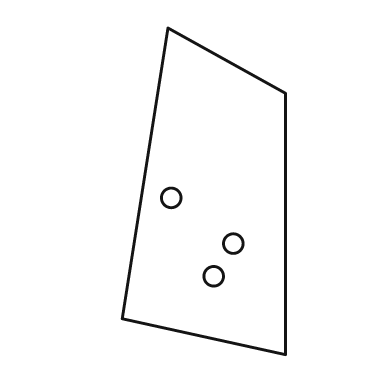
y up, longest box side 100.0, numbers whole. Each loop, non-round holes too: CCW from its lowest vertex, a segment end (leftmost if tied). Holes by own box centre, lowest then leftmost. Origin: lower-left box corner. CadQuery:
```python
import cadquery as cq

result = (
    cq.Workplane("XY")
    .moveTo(50.0, 0.0)
    .lineTo(50.0, 80.0)
    .lineTo(14.0, 100.0)
    .lineTo(0.0, 11.0)
    .close()
    .moveTo(28.0, 24.0)
    .circle(3.0)
    .moveTo(34.0, 34.0)
    .circle(3.0)
    .moveTo(15.0, 48.0)
    .circle(3.0)
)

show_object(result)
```